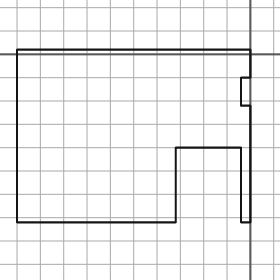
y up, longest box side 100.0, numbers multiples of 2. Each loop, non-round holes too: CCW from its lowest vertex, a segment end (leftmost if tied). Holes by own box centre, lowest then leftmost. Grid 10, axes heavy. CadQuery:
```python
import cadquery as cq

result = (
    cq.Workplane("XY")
    .moveTo(-100.0, -72.0)
    .lineTo(-32.0, -72.0)
    .lineTo(-32.0, -40.0)
    .lineTo(-4.0, -40.0)
    .lineTo(-4.0, -72.0)
    .lineTo(0.0, -72.0)
    .lineTo(0.0, -22.0)
    .lineTo(-4.0, -22.0)
    .lineTo(-4.0, -10.0)
    .lineTo(0.0, -10.0)
    .lineTo(0.0, 2.0)
    .lineTo(-100.0, 2.0)
    .close()
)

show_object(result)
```